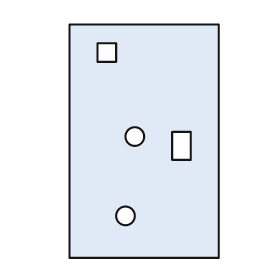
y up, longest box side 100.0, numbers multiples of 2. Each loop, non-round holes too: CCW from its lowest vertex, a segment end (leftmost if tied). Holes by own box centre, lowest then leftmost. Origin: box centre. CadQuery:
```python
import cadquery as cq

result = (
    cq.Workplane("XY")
    .moveTo(-32.0, -50.0)
    .lineTo(32.0, -50.0)
    .lineTo(32.0, 50.0)
    .lineTo(-32.0, 50.0)
    .close()
    .moveTo(-8.0, -32.0)
    .circle(4.0)
    .moveTo(12.0, -8.0)
    .lineTo(20.0, -8.0)
    .lineTo(20.0, 4.0)
    .lineTo(12.0, 4.0)
    .close()
    .moveTo(-4.0, 2.0)
    .circle(4.0)
    .moveTo(-20.0, 34.0)
    .lineTo(-12.0, 34.0)
    .lineTo(-12.0, 42.0)
    .lineTo(-20.0, 42.0)
    .close()
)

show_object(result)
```